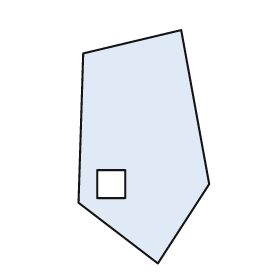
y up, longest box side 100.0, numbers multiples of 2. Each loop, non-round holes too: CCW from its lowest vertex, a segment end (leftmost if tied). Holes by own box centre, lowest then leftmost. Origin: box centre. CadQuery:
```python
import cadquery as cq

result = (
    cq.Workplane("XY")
    .moveTo(6.0, -50.0)
    .lineTo(28.0, -16.0)
    .lineTo(16.0, 50.0)
    .lineTo(-26.0, 40.0)
    .lineTo(-28.0, -24.0)
    .close()
    .moveTo(-20.0, -22.0)
    .lineTo(-8.0, -22.0)
    .lineTo(-8.0, -10.0)
    .lineTo(-20.0, -10.0)
    .close()
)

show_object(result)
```